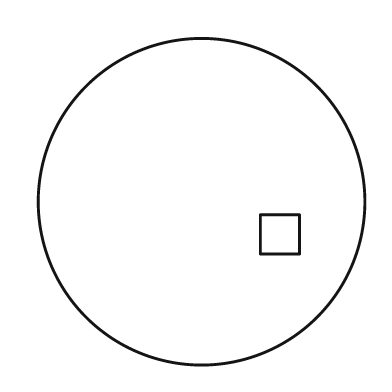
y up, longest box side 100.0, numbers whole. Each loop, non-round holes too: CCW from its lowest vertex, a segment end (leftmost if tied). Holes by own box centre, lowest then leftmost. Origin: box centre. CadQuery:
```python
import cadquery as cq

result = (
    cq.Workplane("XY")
    .moveTo(0.0, 0.0)
    .circle(50.0)
    .moveTo(18.0, -16.0)
    .lineTo(30.0, -16.0)
    .lineTo(30.0, -4.0)
    .lineTo(18.0, -4.0)
    .close()
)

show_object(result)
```